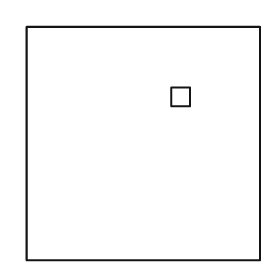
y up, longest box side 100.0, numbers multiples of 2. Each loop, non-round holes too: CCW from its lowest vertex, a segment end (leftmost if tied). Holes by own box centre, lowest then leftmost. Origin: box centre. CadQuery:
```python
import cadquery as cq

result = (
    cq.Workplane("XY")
    .moveTo(-50.0, -50.0)
    .lineTo(50.0, -50.0)
    .lineTo(50.0, 50.0)
    .lineTo(-50.0, 50.0)
    .close()
    .moveTo(12.0, 16.0)
    .lineTo(20.0, 16.0)
    .lineTo(20.0, 24.0)
    .lineTo(12.0, 24.0)
    .close()
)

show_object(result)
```